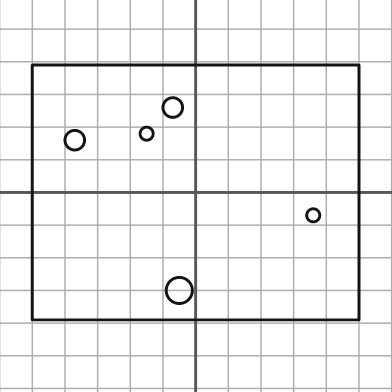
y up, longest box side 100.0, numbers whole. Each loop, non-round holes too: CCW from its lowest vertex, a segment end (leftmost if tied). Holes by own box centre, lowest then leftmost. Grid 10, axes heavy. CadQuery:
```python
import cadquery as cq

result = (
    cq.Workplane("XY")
    .moveTo(-50.0, -39.0)
    .lineTo(50.0, -39.0)
    .lineTo(50.0, 39.0)
    .lineTo(-50.0, 39.0)
    .close()
    .moveTo(-5.0, -30.0)
    .circle(4.0)
    .moveTo(36.0, -7.0)
    .circle(2.0)
    .moveTo(-37.0, 16.0)
    .circle(3.0)
    .moveTo(-15.0, 18.0)
    .circle(2.0)
    .moveTo(-7.0, 26.0)
    .circle(3.0)
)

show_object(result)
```